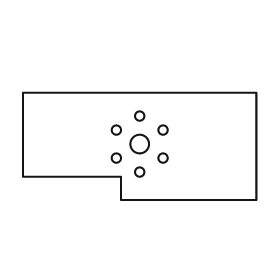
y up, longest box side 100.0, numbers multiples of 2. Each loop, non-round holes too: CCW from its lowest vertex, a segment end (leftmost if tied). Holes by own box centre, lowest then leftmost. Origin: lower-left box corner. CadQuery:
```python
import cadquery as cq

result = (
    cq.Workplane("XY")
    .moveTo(42.0, 0.0)
    .lineTo(100.0, 0.0)
    .lineTo(100.0, 46.0)
    .lineTo(0.0, 46.0)
    .lineTo(0.0, 10.0)
    .lineTo(42.0, 10.0)
    .close()
    .moveTo(50.0, 12.0)
    .circle(2.0)
    .moveTo(40.0, 18.0)
    .circle(2.0)
    .moveTo(60.0, 18.0)
    .circle(2.0)
    .moveTo(50.0, 24.0)
    .circle(4.0)
    .moveTo(40.0, 30.0)
    .circle(2.0)
    .moveTo(60.0, 30.0)
    .circle(2.0)
    .moveTo(50.0, 36.0)
    .circle(2.0)
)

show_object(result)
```